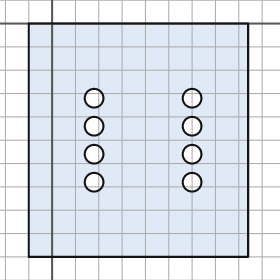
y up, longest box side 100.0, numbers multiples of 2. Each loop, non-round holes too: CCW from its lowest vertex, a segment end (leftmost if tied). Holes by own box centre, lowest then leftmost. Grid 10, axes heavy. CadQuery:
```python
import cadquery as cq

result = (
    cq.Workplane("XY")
    .moveTo(-10.0, -100.0)
    .lineTo(84.0, -100.0)
    .lineTo(84.0, 0.0)
    .lineTo(-10.0, 0.0)
    .close()
    .moveTo(18.0, -68.0)
    .circle(4.0)
    .moveTo(60.0, -68.0)
    .circle(4.0)
    .moveTo(18.0, -56.0)
    .circle(4.0)
    .moveTo(60.0, -56.0)
    .circle(4.0)
    .moveTo(18.0, -44.0)
    .circle(4.0)
    .moveTo(60.0, -44.0)
    .circle(4.0)
    .moveTo(18.0, -32.0)
    .circle(4.0)
    .moveTo(60.0, -32.0)
    .circle(4.0)
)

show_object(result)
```